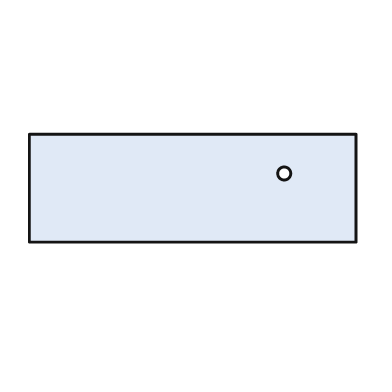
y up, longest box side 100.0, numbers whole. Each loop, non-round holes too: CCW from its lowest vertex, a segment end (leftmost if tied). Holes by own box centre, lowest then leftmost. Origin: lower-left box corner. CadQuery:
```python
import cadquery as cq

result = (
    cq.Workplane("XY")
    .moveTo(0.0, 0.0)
    .lineTo(100.0, 0.0)
    .lineTo(100.0, 33.0)
    .lineTo(0.0, 33.0)
    .close()
    .moveTo(78.0, 21.0)
    .circle(2.0)
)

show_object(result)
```